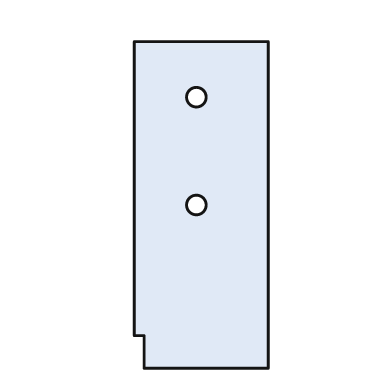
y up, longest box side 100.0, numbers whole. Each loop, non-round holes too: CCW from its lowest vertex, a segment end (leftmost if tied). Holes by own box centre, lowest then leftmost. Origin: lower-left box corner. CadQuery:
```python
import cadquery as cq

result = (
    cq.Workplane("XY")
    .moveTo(3.0, 0.0)
    .lineTo(41.0, 0.0)
    .lineTo(41.0, 100.0)
    .lineTo(0.0, 100.0)
    .lineTo(0.0, 10.0)
    .lineTo(3.0, 10.0)
    .close()
    .moveTo(19.0, 50.0)
    .circle(3.0)
    .moveTo(19.0, 83.0)
    .circle(3.0)
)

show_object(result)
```